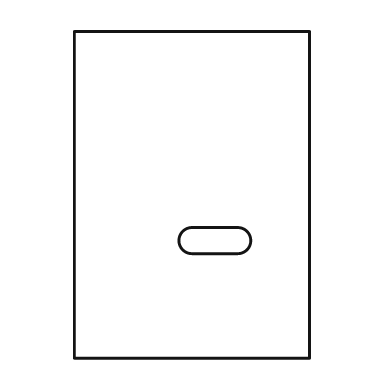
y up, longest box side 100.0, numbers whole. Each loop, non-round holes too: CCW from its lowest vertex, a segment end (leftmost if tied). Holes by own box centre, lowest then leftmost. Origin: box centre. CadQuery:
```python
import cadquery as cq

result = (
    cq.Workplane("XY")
    .moveTo(-36.0, -50.0)
    .lineTo(36.0, -50.0)
    .lineTo(36.0, 50.0)
    .lineTo(-36.0, 50.0)
    .close()
    .moveTo(0.0, -18.0)
    .lineTo(14.0, -18.0)
    .threePointArc((18.0, -14.0), (14.0, -10.0))
    .lineTo(0.0, -10.0)
    .threePointArc((-4.0, -14.0), (0.0, -18.0))
    .close()
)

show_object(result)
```